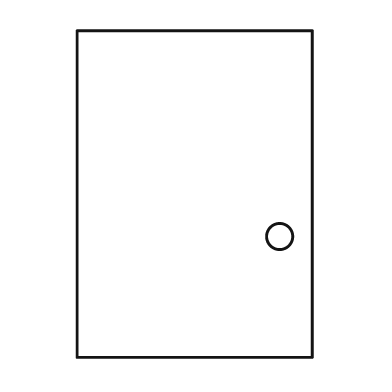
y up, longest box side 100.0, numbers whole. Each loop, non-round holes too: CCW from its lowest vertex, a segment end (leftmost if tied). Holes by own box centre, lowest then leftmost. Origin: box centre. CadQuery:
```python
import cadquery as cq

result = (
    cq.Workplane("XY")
    .moveTo(-36.0, -50.0)
    .lineTo(36.0, -50.0)
    .lineTo(36.0, 50.0)
    .lineTo(-36.0, 50.0)
    .close()
    .moveTo(26.0, -13.0)
    .circle(4.0)
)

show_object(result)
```